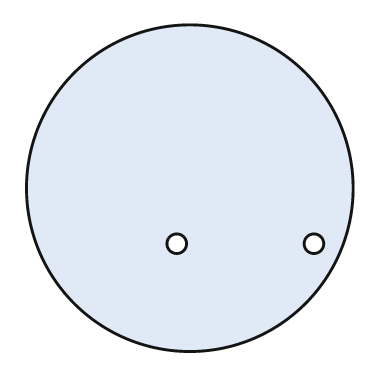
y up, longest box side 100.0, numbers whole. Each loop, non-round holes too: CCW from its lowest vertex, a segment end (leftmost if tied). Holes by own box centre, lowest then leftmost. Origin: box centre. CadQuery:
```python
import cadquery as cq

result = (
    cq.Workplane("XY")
    .moveTo(0.0, 0.0)
    .circle(50.0)
    .moveTo(-4.0, -17.0)
    .circle(3.0)
    .moveTo(38.0, -17.0)
    .circle(3.0)
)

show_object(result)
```